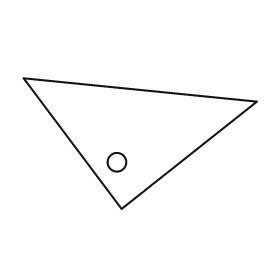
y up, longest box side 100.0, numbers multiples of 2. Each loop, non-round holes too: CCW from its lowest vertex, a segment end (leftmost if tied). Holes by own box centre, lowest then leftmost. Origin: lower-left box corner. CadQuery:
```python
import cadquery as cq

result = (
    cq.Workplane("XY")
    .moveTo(42.0, 0.0)
    .lineTo(100.0, 46.0)
    .lineTo(0.0, 56.0)
    .close()
    .moveTo(40.0, 20.0)
    .circle(4.0)
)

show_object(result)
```